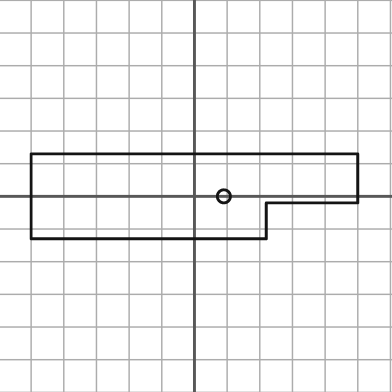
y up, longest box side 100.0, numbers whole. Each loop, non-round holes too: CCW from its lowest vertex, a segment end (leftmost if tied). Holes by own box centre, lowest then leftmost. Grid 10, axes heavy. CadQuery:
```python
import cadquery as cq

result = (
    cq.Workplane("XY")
    .moveTo(-50.0, -13.0)
    .lineTo(22.0, -13.0)
    .lineTo(22.0, -2.0)
    .lineTo(50.0, -2.0)
    .lineTo(50.0, 13.0)
    .lineTo(-50.0, 13.0)
    .close()
    .moveTo(9.0, 0.0)
    .circle(2.0)
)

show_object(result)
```